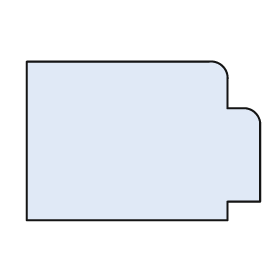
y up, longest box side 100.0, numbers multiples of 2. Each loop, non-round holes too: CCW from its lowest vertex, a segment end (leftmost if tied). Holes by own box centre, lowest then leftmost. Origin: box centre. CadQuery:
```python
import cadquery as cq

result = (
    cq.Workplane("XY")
    .moveTo(-50.0, -34.0)
    .lineTo(36.0, -34.0)
    .lineTo(36.0, -26.0)
    .lineTo(50.0, -26.0)
    .lineTo(50.0, 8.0)
    .threePointArc((48.0, 12.0), (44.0, 14.0))
    .lineTo(36.0, 14.0)
    .lineTo(36.0, 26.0)
    .threePointArc((34.0, 32.0), (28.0, 34.0))
    .lineTo(-50.0, 34.0)
    .close()
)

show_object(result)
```